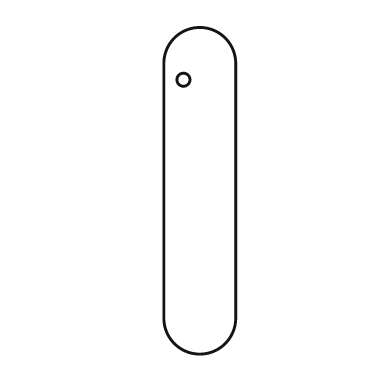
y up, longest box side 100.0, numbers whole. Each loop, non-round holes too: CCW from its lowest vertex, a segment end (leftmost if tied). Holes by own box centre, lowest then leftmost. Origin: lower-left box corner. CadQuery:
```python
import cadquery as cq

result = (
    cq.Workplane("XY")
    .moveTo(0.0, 11.0)
    .threePointArc((11.0, 0.0), (22.0, 11.0))
    .lineTo(22.0, 89.0)
    .threePointArc((11.0, 100.0), (0.0, 89.0))
    .close()
    .moveTo(6.0, 84.0)
    .circle(2.0)
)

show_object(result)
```